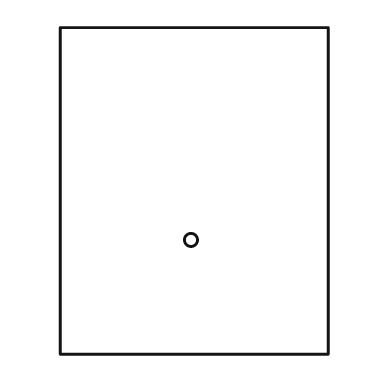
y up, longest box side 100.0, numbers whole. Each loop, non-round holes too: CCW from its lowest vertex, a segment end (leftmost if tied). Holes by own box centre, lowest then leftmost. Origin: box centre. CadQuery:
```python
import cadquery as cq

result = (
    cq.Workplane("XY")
    .moveTo(-41.0, -50.0)
    .lineTo(41.0, -50.0)
    .lineTo(41.0, 50.0)
    .lineTo(-41.0, 50.0)
    .close()
    .moveTo(-1.0, -15.0)
    .circle(2.0)
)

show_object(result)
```